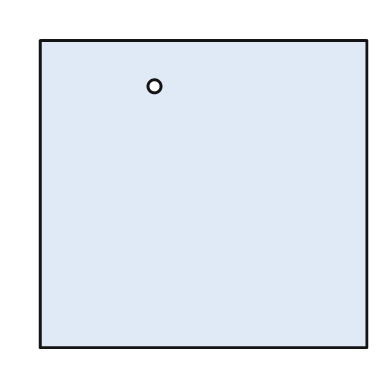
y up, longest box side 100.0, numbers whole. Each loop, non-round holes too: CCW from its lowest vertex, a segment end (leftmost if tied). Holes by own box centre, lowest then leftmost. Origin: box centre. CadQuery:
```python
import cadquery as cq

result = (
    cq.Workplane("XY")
    .moveTo(-50.0, -47.0)
    .lineTo(50.0, -47.0)
    .lineTo(50.0, 47.0)
    .lineTo(-50.0, 47.0)
    .close()
    .moveTo(-15.0, 33.0)
    .circle(2.0)
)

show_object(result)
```